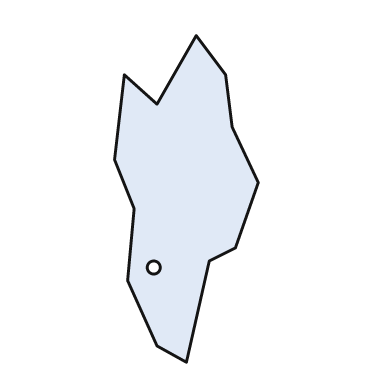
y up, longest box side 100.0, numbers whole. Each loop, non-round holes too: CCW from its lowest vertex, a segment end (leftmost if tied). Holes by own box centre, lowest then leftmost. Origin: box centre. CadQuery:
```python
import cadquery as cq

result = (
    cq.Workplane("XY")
    .moveTo(0.0, -50.0)
    .lineTo(7.0, -19.0)
    .lineTo(15.0, -15.0)
    .lineTo(22.0, 5.0)
    .lineTo(14.0, 22.0)
    .lineTo(12.0, 38.0)
    .lineTo(3.0, 50.0)
    .lineTo(-9.0, 29.0)
    .lineTo(-19.0, 38.0)
    .lineTo(-22.0, 12.0)
    .lineTo(-16.0, -3.0)
    .lineTo(-18.0, -25.0)
    .lineTo(-9.0, -45.0)
    .close()
    .moveTo(-10.0, -21.0)
    .circle(2.0)
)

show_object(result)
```